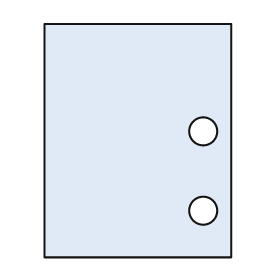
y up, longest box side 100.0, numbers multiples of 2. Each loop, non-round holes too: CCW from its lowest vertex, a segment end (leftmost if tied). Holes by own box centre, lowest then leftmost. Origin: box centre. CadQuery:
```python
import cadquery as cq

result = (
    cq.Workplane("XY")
    .moveTo(-40.0, -50.0)
    .lineTo(40.0, -50.0)
    .lineTo(40.0, 50.0)
    .lineTo(-40.0, 50.0)
    .close()
    .moveTo(28.0, -30.0)
    .circle(6.0)
    .moveTo(28.0, 4.0)
    .circle(6.0)
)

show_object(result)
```